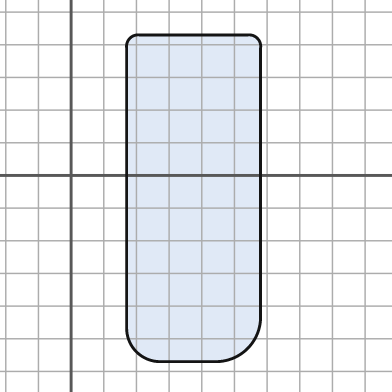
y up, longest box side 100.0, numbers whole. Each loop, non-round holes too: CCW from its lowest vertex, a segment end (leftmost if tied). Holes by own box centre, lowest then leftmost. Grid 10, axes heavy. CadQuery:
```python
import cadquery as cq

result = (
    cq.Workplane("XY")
    .moveTo(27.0, -57.0)
    .lineTo(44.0, -57.0)
    .threePointArc((54.0, -53.0), (58.0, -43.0))
    .lineTo(58.0, 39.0)
    .threePointArc((57.0, 42.0), (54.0, 43.0))
    .lineTo(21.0, 43.0)
    .threePointArc((18.0, 42.0), (17.0, 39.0))
    .lineTo(17.0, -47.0)
    .threePointArc((20.0, -54.0), (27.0, -57.0))
    .close()
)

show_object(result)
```